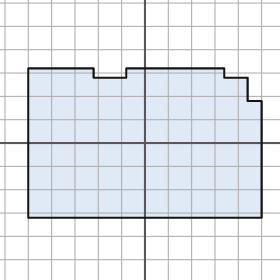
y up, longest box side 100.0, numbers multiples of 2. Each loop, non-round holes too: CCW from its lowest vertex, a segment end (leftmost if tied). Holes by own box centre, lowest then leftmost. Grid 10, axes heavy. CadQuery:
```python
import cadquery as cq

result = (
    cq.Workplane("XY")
    .moveTo(-50.0, -32.0)
    .lineTo(50.0, -32.0)
    .lineTo(50.0, 18.0)
    .lineTo(44.0, 18.0)
    .lineTo(44.0, 28.0)
    .lineTo(34.0, 28.0)
    .lineTo(34.0, 32.0)
    .lineTo(-8.0, 32.0)
    .lineTo(-8.0, 28.0)
    .lineTo(-22.0, 28.0)
    .lineTo(-22.0, 32.0)
    .lineTo(-50.0, 32.0)
    .close()
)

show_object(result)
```